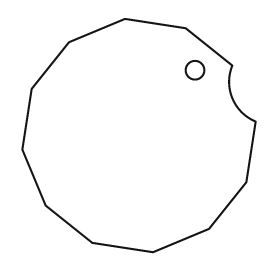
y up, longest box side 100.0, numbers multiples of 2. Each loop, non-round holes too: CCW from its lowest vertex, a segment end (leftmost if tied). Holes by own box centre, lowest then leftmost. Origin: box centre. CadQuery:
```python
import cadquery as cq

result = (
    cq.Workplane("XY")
    .moveTo(6.0, -50.0)
    .lineTo(30.0, -40.0)
    .lineTo(46.0, -20.0)
    .lineTo(50.0, 6.0)
    .threePointArc((40.0, 16.0), (40.0, 30.0))
    .lineTo(20.0, 46.0)
    .lineTo(-6.0, 50.0)
    .lineTo(-30.0, 40.0)
    .lineTo(-46.0, 20.0)
    .lineTo(-50.0, -6.0)
    .lineTo(-40.0, -30.0)
    .lineTo(-20.0, -46.0)
    .close()
    .moveTo(24.0, 28.0)
    .circle(4.0)
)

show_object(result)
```